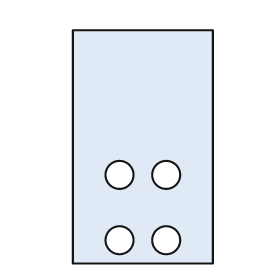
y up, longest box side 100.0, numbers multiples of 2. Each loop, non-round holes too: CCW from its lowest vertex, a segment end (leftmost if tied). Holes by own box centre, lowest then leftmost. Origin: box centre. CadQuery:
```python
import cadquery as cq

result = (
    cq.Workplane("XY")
    .moveTo(-30.0, -50.0)
    .lineTo(30.0, -50.0)
    .lineTo(30.0, 50.0)
    .lineTo(-30.0, 50.0)
    .close()
    .moveTo(-10.0, -40.0)
    .circle(6.0)
    .moveTo(10.0, -40.0)
    .circle(6.0)
    .moveTo(-10.0, -12.0)
    .circle(6.0)
    .moveTo(10.0, -12.0)
    .circle(6.0)
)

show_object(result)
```